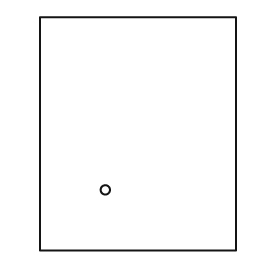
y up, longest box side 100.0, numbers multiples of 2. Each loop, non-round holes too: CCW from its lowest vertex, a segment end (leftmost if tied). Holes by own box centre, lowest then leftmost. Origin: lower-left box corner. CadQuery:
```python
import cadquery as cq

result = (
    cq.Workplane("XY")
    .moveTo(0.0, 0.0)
    .lineTo(84.0, 0.0)
    .lineTo(84.0, 100.0)
    .lineTo(0.0, 100.0)
    .close()
    .moveTo(28.0, 26.0)
    .circle(2.0)
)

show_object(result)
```